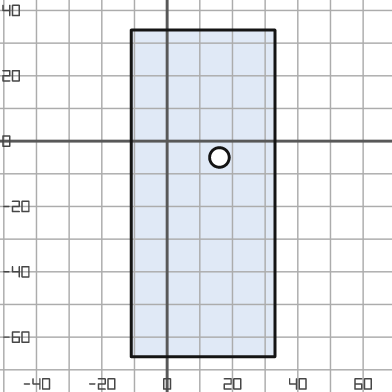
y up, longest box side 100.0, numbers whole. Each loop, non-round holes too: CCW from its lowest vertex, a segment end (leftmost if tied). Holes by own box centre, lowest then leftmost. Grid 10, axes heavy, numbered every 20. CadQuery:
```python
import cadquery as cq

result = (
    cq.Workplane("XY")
    .moveTo(-11.0, -66.0)
    .lineTo(33.0, -66.0)
    .lineTo(33.0, 34.0)
    .lineTo(-11.0, 34.0)
    .close()
    .moveTo(16.0, -5.0)
    .circle(3.0)
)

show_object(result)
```